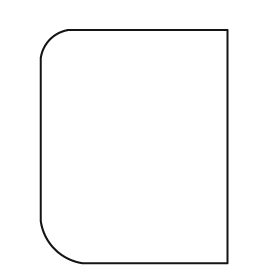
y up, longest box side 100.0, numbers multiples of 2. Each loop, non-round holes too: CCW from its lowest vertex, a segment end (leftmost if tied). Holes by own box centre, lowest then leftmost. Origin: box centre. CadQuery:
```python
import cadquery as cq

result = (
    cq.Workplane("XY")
    .moveTo(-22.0, -50.0)
    .lineTo(40.0, -50.0)
    .lineTo(40.0, 50.0)
    .lineTo(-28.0, 50.0)
    .threePointArc((-36.0, 46.0), (-40.0, 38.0))
    .lineTo(-40.0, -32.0)
    .threePointArc((-34.0, -44.0), (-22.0, -50.0))
    .close()
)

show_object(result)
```